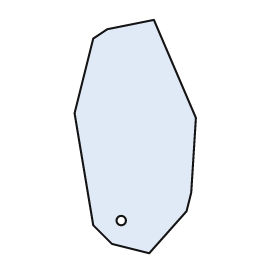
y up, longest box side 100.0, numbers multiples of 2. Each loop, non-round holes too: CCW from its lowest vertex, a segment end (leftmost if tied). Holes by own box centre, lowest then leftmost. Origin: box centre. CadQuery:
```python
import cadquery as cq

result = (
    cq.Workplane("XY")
    .moveTo(6.0, -50.0)
    .lineTo(22.0, -32.0)
    .lineTo(24.0, -24.0)
    .lineTo(26.0, 8.0)
    .lineTo(8.0, 50.0)
    .lineTo(-12.0, 46.0)
    .lineTo(-18.0, 42.0)
    .lineTo(-26.0, 10.0)
    .lineTo(-18.0, -38.0)
    .lineTo(-10.0, -46.0)
    .close()
    .moveTo(-6.0, -36.0)
    .circle(2.0)
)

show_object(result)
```